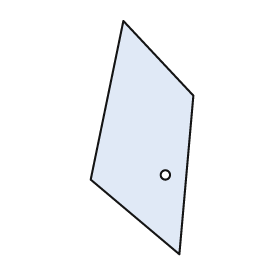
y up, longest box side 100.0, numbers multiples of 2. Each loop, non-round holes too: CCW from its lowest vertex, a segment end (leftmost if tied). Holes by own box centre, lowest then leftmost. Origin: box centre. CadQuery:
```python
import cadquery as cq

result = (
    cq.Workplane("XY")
    .moveTo(16.0, -50.0)
    .lineTo(22.0, 18.0)
    .lineTo(-8.0, 50.0)
    .lineTo(-22.0, -18.0)
    .close()
    .moveTo(10.0, -16.0)
    .circle(2.0)
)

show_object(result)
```